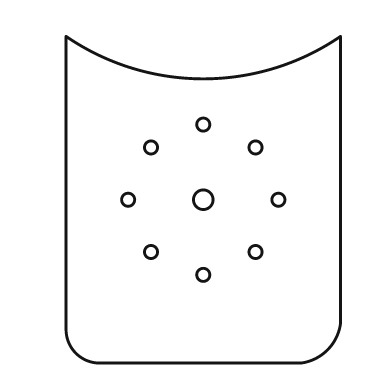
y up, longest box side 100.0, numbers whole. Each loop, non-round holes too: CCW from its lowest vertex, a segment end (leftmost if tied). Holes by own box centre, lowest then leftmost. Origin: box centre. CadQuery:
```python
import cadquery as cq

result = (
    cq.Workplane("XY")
    .moveTo(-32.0, -50.0)
    .lineTo(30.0, -50.0)
    .threePointArc((38.0, -46.0), (42.0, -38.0))
    .lineTo(42.0, 50.0)
    .threePointArc((0.0, 37.0), (-42.0, 50.0))
    .lineTo(-42.0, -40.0)
    .threePointArc((-39.0, -47.0), (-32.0, -50.0))
    .close()
    .moveTo(0.0, -23.0)
    .circle(2.0)
    .moveTo(-16.0, -16.0)
    .circle(2.0)
    .moveTo(16.0, -16.0)
    .circle(2.0)
    .moveTo(-23.0, 0.0)
    .circle(2.0)
    .moveTo(0.0, 0.0)
    .circle(3.0)
    .moveTo(23.0, 0.0)
    .circle(2.0)
    .moveTo(-16.0, 16.0)
    .circle(2.0)
    .moveTo(16.0, 16.0)
    .circle(2.0)
    .moveTo(0.0, 23.0)
    .circle(2.0)
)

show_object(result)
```